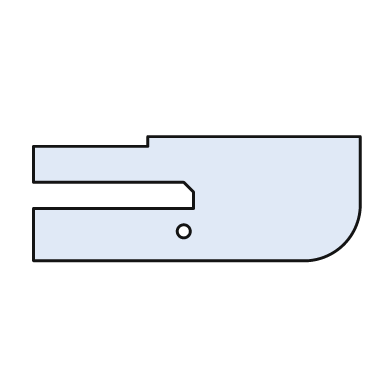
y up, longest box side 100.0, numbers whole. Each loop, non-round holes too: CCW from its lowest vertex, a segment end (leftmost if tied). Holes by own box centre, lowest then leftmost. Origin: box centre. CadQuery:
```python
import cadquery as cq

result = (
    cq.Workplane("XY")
    .moveTo(-50.0, -19.0)
    .lineTo(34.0, -19.0)
    .threePointArc((45.0, -14.0), (50.0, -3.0))
    .lineTo(50.0, 19.0)
    .lineTo(-15.0, 19.0)
    .lineTo(-15.0, 16.0)
    .lineTo(-50.0, 16.0)
    .lineTo(-50.0, 5.0)
    .lineTo(-4.0, 5.0)
    .lineTo(-1.0, 2.0)
    .lineTo(-1.0, -3.0)
    .lineTo(-50.0, -3.0)
    .close()
    .moveTo(-4.0, -10.0)
    .circle(2.0)
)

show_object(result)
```